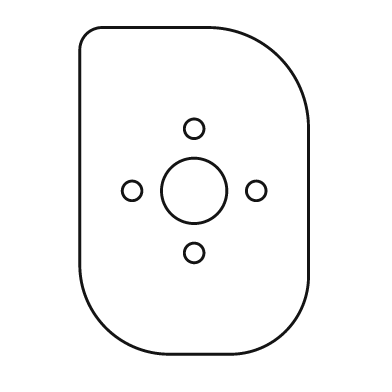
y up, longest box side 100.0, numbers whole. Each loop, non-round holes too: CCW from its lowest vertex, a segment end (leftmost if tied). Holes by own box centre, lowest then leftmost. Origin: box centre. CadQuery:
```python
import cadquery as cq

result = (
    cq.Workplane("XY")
    .moveTo(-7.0, -50.0)
    .lineTo(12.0, -50.0)
    .threePointArc((28.0, -43.0), (35.0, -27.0))
    .lineTo(35.0, 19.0)
    .threePointArc((26.0, 41.0), (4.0, 50.0))
    .lineTo(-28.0, 50.0)
    .threePointArc((-33.0, 48.0), (-35.0, 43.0))
    .lineTo(-35.0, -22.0)
    .threePointArc((-27.0, -42.0), (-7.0, -50.0))
    .close()
    .moveTo(0.0, -19.0)
    .circle(3.0)
    .moveTo(-19.0, 0.0)
    .circle(3.0)
    .moveTo(0.0, 0.0)
    .circle(10.0)
    .moveTo(19.0, 0.0)
    .circle(3.0)
    .moveTo(0.0, 19.0)
    .circle(3.0)
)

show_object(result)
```